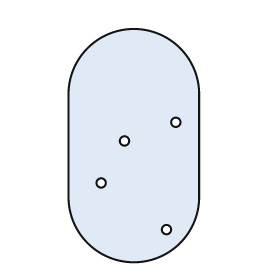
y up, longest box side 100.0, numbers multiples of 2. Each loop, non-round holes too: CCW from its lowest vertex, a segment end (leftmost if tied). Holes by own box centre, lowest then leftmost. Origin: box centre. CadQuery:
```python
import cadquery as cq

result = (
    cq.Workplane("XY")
    .moveTo(-28.0, -22.0)
    .threePointArc((0.0, -50.0), (28.0, -22.0))
    .lineTo(28.0, 22.0)
    .threePointArc((0.0, 50.0), (-28.0, 22.0))
    .close()
    .moveTo(14.0, -36.0)
    .circle(2.0)
    .moveTo(-14.0, -16.0)
    .circle(2.0)
    .moveTo(-4.0, 2.0)
    .circle(2.0)
    .moveTo(18.0, 10.0)
    .circle(2.0)
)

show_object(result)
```